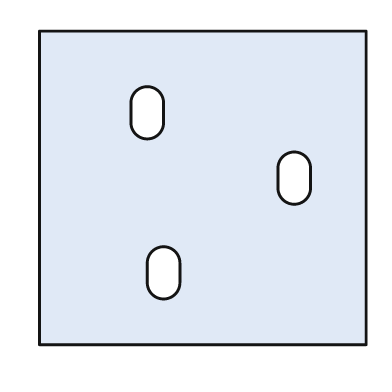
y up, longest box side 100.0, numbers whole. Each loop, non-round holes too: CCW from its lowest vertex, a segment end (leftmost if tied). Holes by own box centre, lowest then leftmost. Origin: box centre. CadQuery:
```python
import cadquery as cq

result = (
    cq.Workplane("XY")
    .moveTo(-50.0, -48.0)
    .lineTo(50.0, -48.0)
    .lineTo(50.0, 48.0)
    .lineTo(-50.0, 48.0)
    .close()
    .moveTo(-17.0, -29.0)
    .threePointArc((-12.0, -34.0), (-7.0, -29.0))
    .lineTo(-7.0, -23.0)
    .threePointArc((-12.0, -18.0), (-17.0, -23.0))
    .close()
    .moveTo(23.0, 0.0)
    .threePointArc((28.0, -5.0), (33.0, 0.0))
    .lineTo(33.0, 6.0)
    .threePointArc((28.0, 11.0), (23.0, 6.0))
    .close()
    .moveTo(-22.0, 20.0)
    .threePointArc((-17.0, 15.0), (-12.0, 20.0))
    .lineTo(-12.0, 26.0)
    .threePointArc((-17.0, 31.0), (-22.0, 26.0))
    .close()
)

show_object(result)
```